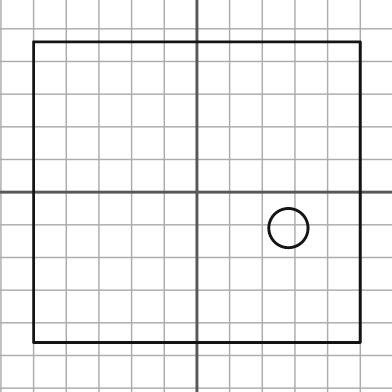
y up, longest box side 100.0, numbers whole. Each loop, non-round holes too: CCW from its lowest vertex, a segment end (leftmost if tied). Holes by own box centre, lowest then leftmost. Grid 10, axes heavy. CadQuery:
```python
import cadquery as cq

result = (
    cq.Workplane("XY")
    .moveTo(-50.0, -46.0)
    .lineTo(50.0, -46.0)
    .lineTo(50.0, 46.0)
    .lineTo(-50.0, 46.0)
    .close()
    .moveTo(28.0, -11.0)
    .circle(6.0)
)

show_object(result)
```